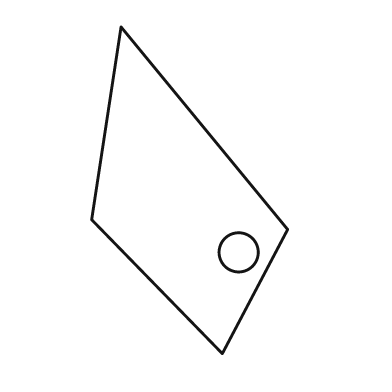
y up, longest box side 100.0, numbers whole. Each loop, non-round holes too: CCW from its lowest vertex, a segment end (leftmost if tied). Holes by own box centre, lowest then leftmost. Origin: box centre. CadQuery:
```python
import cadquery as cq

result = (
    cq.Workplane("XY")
    .moveTo(10.0, -50.0)
    .lineTo(30.0, -12.0)
    .lineTo(-21.0, 50.0)
    .lineTo(-30.0, -9.0)
    .close()
    .moveTo(15.0, -19.0)
    .circle(6.0)
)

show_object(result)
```